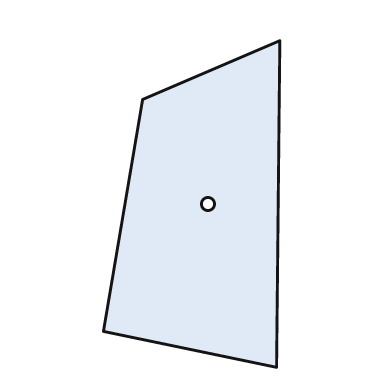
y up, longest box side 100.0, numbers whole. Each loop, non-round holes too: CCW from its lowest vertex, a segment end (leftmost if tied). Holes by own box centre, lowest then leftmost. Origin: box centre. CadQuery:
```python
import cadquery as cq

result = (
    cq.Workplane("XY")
    .moveTo(26.0, -50.0)
    .lineTo(27.0, 50.0)
    .lineTo(-15.0, 32.0)
    .lineTo(-27.0, -39.0)
    .close()
    .moveTo(5.0, 0.0)
    .circle(2.0)
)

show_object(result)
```